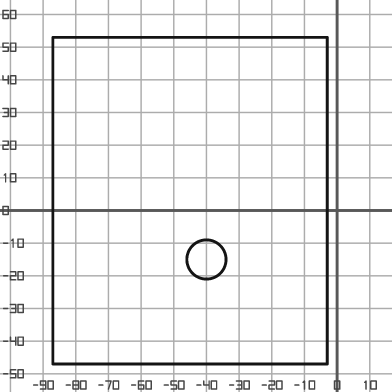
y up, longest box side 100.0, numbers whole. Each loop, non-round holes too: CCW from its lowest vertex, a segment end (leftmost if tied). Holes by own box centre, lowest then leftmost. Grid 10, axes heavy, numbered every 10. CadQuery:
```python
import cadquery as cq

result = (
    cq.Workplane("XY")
    .moveTo(-87.0, -47.0)
    .lineTo(-3.0, -47.0)
    .lineTo(-3.0, 53.0)
    .lineTo(-87.0, 53.0)
    .close()
    .moveTo(-40.0, -15.0)
    .circle(6.0)
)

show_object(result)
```